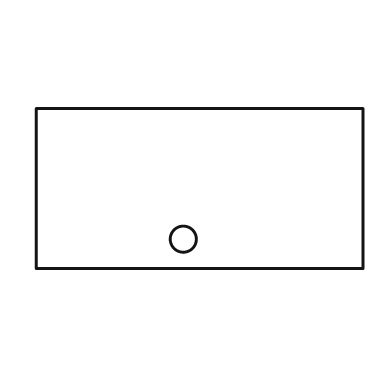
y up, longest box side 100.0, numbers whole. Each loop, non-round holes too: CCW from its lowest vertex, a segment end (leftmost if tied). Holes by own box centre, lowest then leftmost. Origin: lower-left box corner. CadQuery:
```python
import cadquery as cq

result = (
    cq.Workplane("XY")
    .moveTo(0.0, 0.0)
    .lineTo(100.0, 0.0)
    .lineTo(100.0, 49.0)
    .lineTo(0.0, 49.0)
    .close()
    .moveTo(45.0, 9.0)
    .circle(4.0)
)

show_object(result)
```